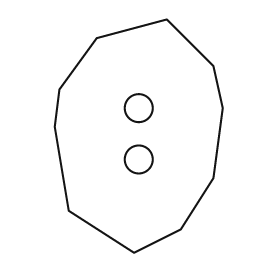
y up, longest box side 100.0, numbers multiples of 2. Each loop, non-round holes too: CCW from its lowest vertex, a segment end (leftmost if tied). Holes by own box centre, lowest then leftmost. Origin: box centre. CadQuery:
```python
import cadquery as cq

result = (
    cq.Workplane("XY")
    .moveTo(-2.0, -50.0)
    .lineTo(18.0, -40.0)
    .lineTo(32.0, -18.0)
    .lineTo(36.0, 12.0)
    .lineTo(32.0, 30.0)
    .lineTo(12.0, 50.0)
    .lineTo(-18.0, 42.0)
    .lineTo(-34.0, 20.0)
    .lineTo(-36.0, 4.0)
    .lineTo(-30.0, -32.0)
    .close()
    .moveTo(0.0, -10.0)
    .circle(6.0)
    .moveTo(0.0, 12.0)
    .circle(6.0)
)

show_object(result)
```